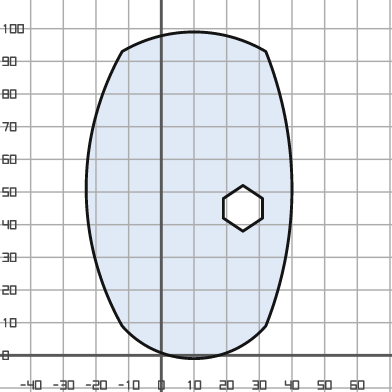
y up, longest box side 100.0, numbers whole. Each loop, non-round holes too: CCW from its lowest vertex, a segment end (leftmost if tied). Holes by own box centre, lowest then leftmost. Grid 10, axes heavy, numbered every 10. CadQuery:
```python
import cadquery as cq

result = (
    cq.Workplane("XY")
    .moveTo(-12.0, 9.0)
    .threePointArc((10.0, -1.0), (32.0, 9.0))
    .threePointArc((40.0, 51.0), (32.0, 93.0))
    .threePointArc((10.0, 99.0), (-12.0, 93.0))
    .threePointArc((-23.0, 51.0), (-12.0, 9.0))
    .close()
    .moveTo(25.0, 38.0)
    .lineTo(31.0, 42.0)
    .lineTo(31.0, 48.0)
    .lineTo(25.0, 52.0)
    .lineTo(19.0, 48.0)
    .lineTo(19.0, 42.0)
    .close()
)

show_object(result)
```